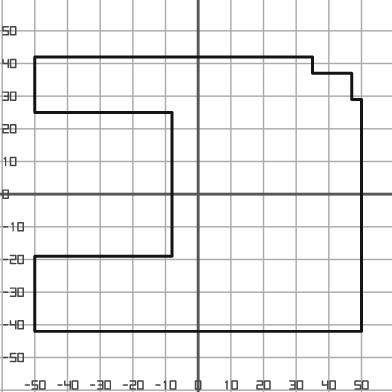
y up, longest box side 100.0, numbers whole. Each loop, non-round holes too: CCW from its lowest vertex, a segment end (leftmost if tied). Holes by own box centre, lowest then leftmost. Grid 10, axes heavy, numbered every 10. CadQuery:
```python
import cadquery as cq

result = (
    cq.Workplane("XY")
    .moveTo(-50.0, -42.0)
    .lineTo(50.0, -42.0)
    .lineTo(50.0, 29.0)
    .lineTo(47.0, 29.0)
    .lineTo(47.0, 37.0)
    .lineTo(35.0, 37.0)
    .lineTo(35.0, 42.0)
    .lineTo(-50.0, 42.0)
    .lineTo(-50.0, 25.0)
    .lineTo(-8.0, 25.0)
    .lineTo(-8.0, -19.0)
    .lineTo(-50.0, -19.0)
    .close()
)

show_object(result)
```